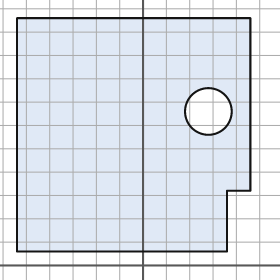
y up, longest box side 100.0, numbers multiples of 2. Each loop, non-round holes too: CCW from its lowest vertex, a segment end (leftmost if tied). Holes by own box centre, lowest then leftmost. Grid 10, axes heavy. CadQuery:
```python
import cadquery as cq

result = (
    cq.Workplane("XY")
    .moveTo(-54.0, 6.0)
    .lineTo(36.0, 6.0)
    .lineTo(36.0, 32.0)
    .lineTo(46.0, 32.0)
    .lineTo(46.0, 106.0)
    .lineTo(-54.0, 106.0)
    .close()
    .moveTo(28.0, 66.0)
    .circle(10.0)
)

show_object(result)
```